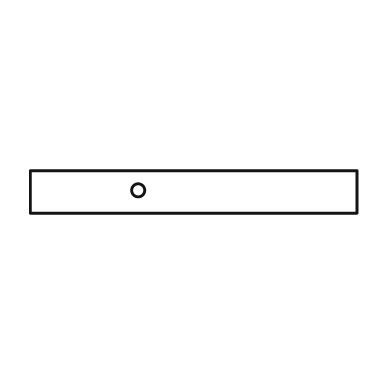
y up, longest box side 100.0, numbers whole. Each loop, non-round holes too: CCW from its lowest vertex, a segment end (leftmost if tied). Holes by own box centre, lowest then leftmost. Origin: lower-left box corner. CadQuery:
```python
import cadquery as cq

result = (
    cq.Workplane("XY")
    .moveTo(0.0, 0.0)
    .lineTo(100.0, 0.0)
    .lineTo(100.0, 13.0)
    .lineTo(0.0, 13.0)
    .close()
    .moveTo(33.0, 7.0)
    .circle(2.0)
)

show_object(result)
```